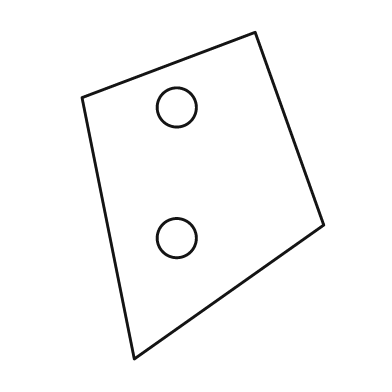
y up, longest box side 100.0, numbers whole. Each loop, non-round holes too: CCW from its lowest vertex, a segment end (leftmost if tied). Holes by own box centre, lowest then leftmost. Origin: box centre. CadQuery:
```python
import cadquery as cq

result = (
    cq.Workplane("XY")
    .moveTo(-21.0, -50.0)
    .lineTo(37.0, -9.0)
    .lineTo(16.0, 50.0)
    .lineTo(-37.0, 30.0)
    .close()
    .moveTo(-8.0, -13.0)
    .circle(6.0)
    .moveTo(-8.0, 27.0)
    .circle(6.0)
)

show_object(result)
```